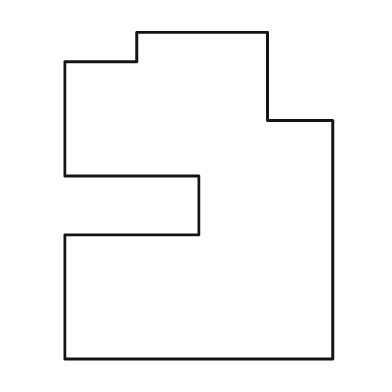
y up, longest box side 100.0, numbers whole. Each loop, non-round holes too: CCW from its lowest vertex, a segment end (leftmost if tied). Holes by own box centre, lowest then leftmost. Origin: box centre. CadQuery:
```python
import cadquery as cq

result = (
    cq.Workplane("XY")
    .moveTo(-41.0, -50.0)
    .lineTo(41.0, -50.0)
    .lineTo(41.0, 23.0)
    .lineTo(21.0, 23.0)
    .lineTo(21.0, 50.0)
    .lineTo(-19.0, 50.0)
    .lineTo(-19.0, 41.0)
    .lineTo(-41.0, 41.0)
    .lineTo(-41.0, 6.0)
    .lineTo(0.0, 6.0)
    .lineTo(0.0, -12.0)
    .lineTo(-41.0, -12.0)
    .close()
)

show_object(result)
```